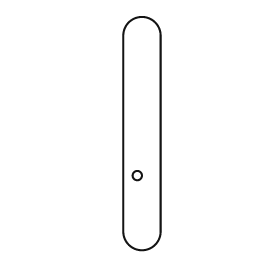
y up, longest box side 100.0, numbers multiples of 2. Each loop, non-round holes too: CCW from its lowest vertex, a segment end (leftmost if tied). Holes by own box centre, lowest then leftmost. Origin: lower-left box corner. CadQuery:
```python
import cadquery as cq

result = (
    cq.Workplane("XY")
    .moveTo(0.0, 8.0)
    .threePointArc((8.0, 0.0), (16.0, 8.0))
    .lineTo(16.0, 92.0)
    .threePointArc((8.0, 100.0), (0.0, 92.0))
    .close()
    .moveTo(6.0, 32.0)
    .circle(2.0)
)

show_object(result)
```